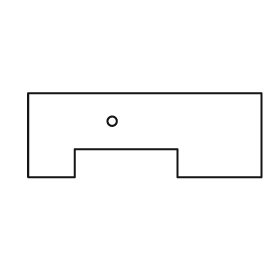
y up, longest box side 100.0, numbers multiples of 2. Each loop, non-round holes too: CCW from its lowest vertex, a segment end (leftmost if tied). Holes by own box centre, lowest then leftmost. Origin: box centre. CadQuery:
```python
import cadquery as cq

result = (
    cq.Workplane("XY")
    .moveTo(-50.0, -18.0)
    .lineTo(-30.0, -18.0)
    .lineTo(-30.0, -6.0)
    .lineTo(14.0, -6.0)
    .lineTo(14.0, -18.0)
    .lineTo(50.0, -18.0)
    .lineTo(50.0, 18.0)
    .lineTo(-50.0, 18.0)
    .close()
    .moveTo(-14.0, 6.0)
    .circle(2.0)
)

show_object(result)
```